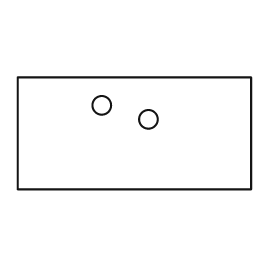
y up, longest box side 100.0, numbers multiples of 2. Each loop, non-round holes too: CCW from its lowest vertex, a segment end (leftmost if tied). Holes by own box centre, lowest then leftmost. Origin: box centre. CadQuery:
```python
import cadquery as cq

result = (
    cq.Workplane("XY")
    .moveTo(-50.0, -24.0)
    .lineTo(50.0, -24.0)
    .lineTo(50.0, 24.0)
    .lineTo(-50.0, 24.0)
    .close()
    .moveTo(6.0, 6.0)
    .circle(4.0)
    .moveTo(-14.0, 12.0)
    .circle(4.0)
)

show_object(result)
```